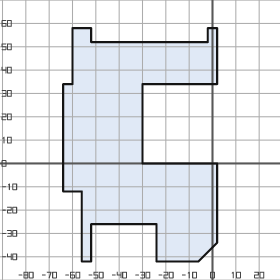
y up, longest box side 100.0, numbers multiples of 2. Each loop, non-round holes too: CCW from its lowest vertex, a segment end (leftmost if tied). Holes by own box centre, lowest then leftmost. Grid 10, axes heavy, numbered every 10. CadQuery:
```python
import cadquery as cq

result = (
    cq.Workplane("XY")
    .moveTo(-56.0, -42.0)
    .lineTo(-52.0, -42.0)
    .lineTo(-52.0, -26.0)
    .lineTo(-24.0, -26.0)
    .lineTo(-24.0, -42.0)
    .lineTo(-6.0, -42.0)
    .lineTo(2.0, -34.0)
    .lineTo(2.0, 0.0)
    .lineTo(-30.0, 0.0)
    .lineTo(-30.0, 34.0)
    .lineTo(2.0, 34.0)
    .lineTo(2.0, 58.0)
    .lineTo(-2.0, 58.0)
    .lineTo(-2.0, 52.0)
    .lineTo(-52.0, 52.0)
    .lineTo(-52.0, 58.0)
    .lineTo(-60.0, 58.0)
    .lineTo(-60.0, 34.0)
    .lineTo(-64.0, 34.0)
    .lineTo(-64.0, -12.0)
    .lineTo(-56.0, -12.0)
    .close()
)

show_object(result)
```